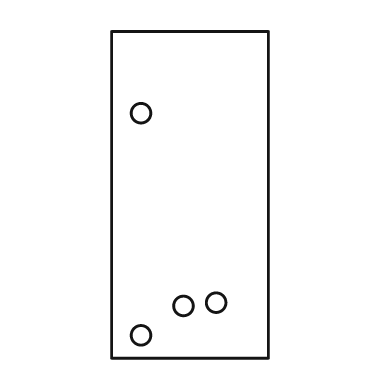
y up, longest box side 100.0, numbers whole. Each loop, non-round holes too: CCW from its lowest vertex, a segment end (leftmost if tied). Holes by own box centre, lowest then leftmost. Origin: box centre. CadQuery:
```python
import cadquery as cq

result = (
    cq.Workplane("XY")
    .moveTo(-24.0, -50.0)
    .lineTo(24.0, -50.0)
    .lineTo(24.0, 50.0)
    .lineTo(-24.0, 50.0)
    .close()
    .moveTo(-15.0, -43.0)
    .circle(3.0)
    .moveTo(-2.0, -34.0)
    .circle(3.0)
    .moveTo(8.0, -33.0)
    .circle(3.0)
    .moveTo(-15.0, 25.0)
    .circle(3.0)
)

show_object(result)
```